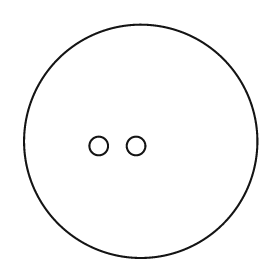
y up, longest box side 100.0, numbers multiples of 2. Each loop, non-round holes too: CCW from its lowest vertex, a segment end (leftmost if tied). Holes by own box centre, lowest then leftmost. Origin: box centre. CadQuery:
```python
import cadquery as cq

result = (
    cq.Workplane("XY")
    .moveTo(0.0, 0.0)
    .circle(50.0)
    .moveTo(-18.0, -2.0)
    .circle(4.0)
    .moveTo(-2.0, -2.0)
    .circle(4.0)
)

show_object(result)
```